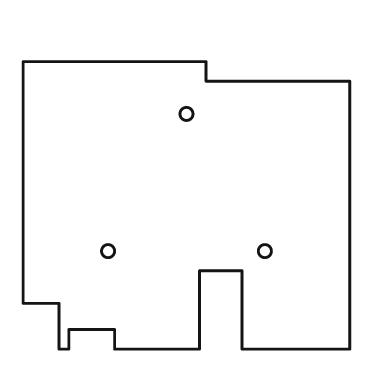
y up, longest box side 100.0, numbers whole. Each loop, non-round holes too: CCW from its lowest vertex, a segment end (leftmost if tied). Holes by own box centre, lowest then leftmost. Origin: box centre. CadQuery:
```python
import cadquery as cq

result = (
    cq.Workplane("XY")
    .moveTo(-39.0, -44.0)
    .lineTo(-36.0, -44.0)
    .lineTo(-36.0, -38.0)
    .lineTo(-22.0, -38.0)
    .lineTo(-22.0, -44.0)
    .lineTo(4.0, -44.0)
    .lineTo(4.0, -20.0)
    .lineTo(17.0, -20.0)
    .lineTo(17.0, -44.0)
    .lineTo(50.0, -44.0)
    .lineTo(50.0, 38.0)
    .lineTo(6.0, 38.0)
    .lineTo(6.0, 44.0)
    .lineTo(-50.0, 44.0)
    .lineTo(-50.0, -30.0)
    .lineTo(-39.0, -30.0)
    .close()
    .moveTo(-24.0, -14.0)
    .circle(2.0)
    .moveTo(24.0, -14.0)
    .circle(2.0)
    .moveTo(0.0, 28.0)
    .circle(2.0)
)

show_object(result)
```